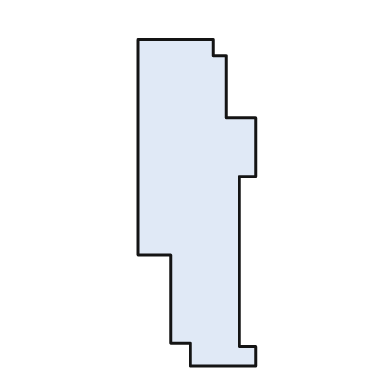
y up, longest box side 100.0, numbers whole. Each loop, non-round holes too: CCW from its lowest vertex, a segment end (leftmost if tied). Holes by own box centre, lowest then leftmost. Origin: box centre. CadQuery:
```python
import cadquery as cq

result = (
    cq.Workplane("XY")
    .moveTo(-2.0, -50.0)
    .lineTo(18.0, -50.0)
    .lineTo(18.0, -44.0)
    .lineTo(13.0, -44.0)
    .lineTo(13.0, 8.0)
    .lineTo(18.0, 8.0)
    .lineTo(18.0, 26.0)
    .lineTo(9.0, 26.0)
    .lineTo(9.0, 45.0)
    .lineTo(5.0, 45.0)
    .lineTo(5.0, 50.0)
    .lineTo(-18.0, 50.0)
    .lineTo(-18.0, -16.0)
    .lineTo(-8.0, -16.0)
    .lineTo(-8.0, -43.0)
    .lineTo(-2.0, -43.0)
    .close()
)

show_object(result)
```